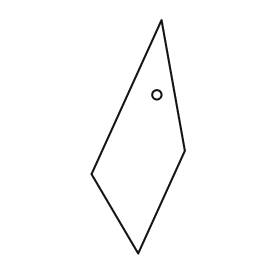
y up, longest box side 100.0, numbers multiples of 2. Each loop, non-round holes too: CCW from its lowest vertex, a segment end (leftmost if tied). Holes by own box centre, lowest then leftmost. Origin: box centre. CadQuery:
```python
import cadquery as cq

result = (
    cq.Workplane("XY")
    .moveTo(0.0, -50.0)
    .lineTo(20.0, -6.0)
    .lineTo(10.0, 50.0)
    .lineTo(-20.0, -16.0)
    .close()
    .moveTo(8.0, 18.0)
    .circle(2.0)
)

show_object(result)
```